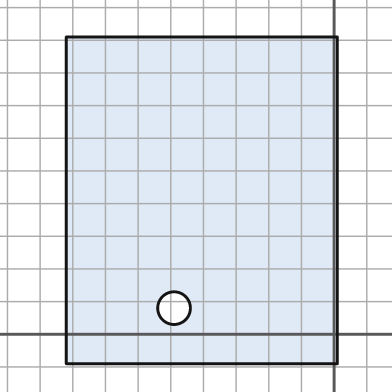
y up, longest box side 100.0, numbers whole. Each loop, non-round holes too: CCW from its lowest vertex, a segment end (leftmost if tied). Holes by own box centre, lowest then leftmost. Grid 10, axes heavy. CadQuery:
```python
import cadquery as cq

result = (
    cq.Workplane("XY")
    .moveTo(-82.0, -9.0)
    .lineTo(1.0, -9.0)
    .lineTo(1.0, 91.0)
    .lineTo(-82.0, 91.0)
    .close()
    .moveTo(-49.0, 8.0)
    .circle(5.0)
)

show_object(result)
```